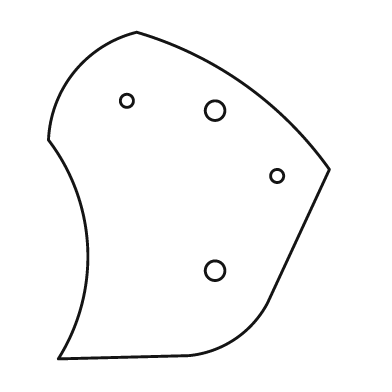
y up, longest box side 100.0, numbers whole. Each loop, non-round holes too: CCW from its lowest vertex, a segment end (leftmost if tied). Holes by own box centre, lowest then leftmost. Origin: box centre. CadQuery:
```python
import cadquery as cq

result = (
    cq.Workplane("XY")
    .moveTo(-40.0, -50.0)
    .lineTo(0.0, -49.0)
    .threePointArc((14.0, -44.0), (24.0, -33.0))
    .lineTo(43.0, 8.0)
    .threePointArc((17.0, 34.0), (-16.0, 50.0))
    .threePointArc((-35.0, 38.0), (-43.0, 17.0))
    .threePointArc((-31.0, -16.0), (-40.0, -50.0))
    .close()
    .moveTo(8.0, -23.0)
    .circle(3.0)
    .moveTo(27.0, 6.0)
    .circle(2.0)
    .moveTo(8.0, 26.0)
    .circle(3.0)
    .moveTo(-19.0, 29.0)
    .circle(2.0)
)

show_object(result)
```